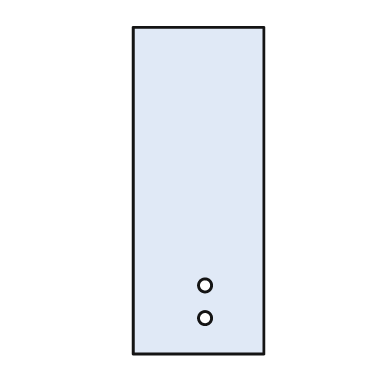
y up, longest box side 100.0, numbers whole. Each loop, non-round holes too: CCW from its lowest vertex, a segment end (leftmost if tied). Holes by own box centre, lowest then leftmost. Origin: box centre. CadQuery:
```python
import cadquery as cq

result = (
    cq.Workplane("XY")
    .moveTo(-20.0, -50.0)
    .lineTo(20.0, -50.0)
    .lineTo(20.0, 50.0)
    .lineTo(-20.0, 50.0)
    .close()
    .moveTo(2.0, -39.0)
    .circle(2.0)
    .moveTo(2.0, -29.0)
    .circle(2.0)
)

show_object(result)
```